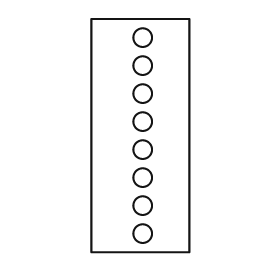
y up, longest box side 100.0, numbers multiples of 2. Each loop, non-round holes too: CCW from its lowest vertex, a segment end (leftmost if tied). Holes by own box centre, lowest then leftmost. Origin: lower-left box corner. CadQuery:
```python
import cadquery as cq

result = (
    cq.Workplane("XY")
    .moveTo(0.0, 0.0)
    .lineTo(42.0, 0.0)
    .lineTo(42.0, 100.0)
    .lineTo(0.0, 100.0)
    .close()
    .moveTo(22.0, 8.0)
    .circle(4.0)
    .moveTo(22.0, 20.0)
    .circle(4.0)
    .moveTo(22.0, 32.0)
    .circle(4.0)
    .moveTo(22.0, 44.0)
    .circle(4.0)
    .moveTo(22.0, 56.0)
    .circle(4.0)
    .moveTo(22.0, 68.0)
    .circle(4.0)
    .moveTo(22.0, 80.0)
    .circle(4.0)
    .moveTo(22.0, 92.0)
    .circle(4.0)
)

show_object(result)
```